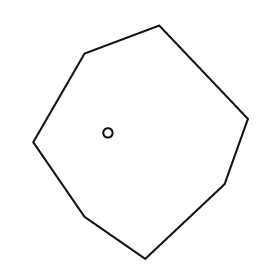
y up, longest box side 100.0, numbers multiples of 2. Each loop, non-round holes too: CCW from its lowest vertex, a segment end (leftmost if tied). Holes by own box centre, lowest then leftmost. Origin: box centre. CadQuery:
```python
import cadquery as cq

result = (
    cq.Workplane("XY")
    .moveTo(2.0, -50.0)
    .lineTo(36.0, -18.0)
    .lineTo(46.0, 10.0)
    .lineTo(8.0, 50.0)
    .lineTo(-24.0, 38.0)
    .lineTo(-46.0, 0.0)
    .lineTo(-24.0, -32.0)
    .close()
    .moveTo(-14.0, 4.0)
    .circle(2.0)
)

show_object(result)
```